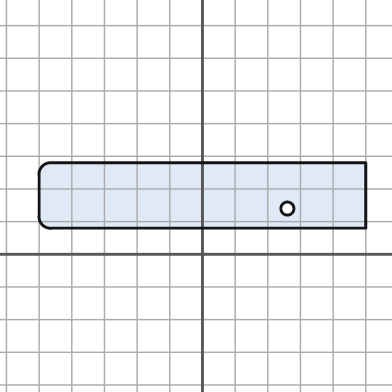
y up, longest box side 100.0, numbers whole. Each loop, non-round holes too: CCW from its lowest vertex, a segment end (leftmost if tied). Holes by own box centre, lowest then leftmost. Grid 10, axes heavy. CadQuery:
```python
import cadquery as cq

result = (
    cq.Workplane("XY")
    .moveTo(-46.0, 8.0)
    .lineTo(50.0, 8.0)
    .lineTo(50.0, 28.0)
    .lineTo(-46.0, 28.0)
    .threePointArc((-49.0, 27.0), (-50.0, 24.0))
    .lineTo(-50.0, 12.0)
    .threePointArc((-49.0, 9.0), (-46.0, 8.0))
    .close()
    .moveTo(26.0, 14.0)
    .circle(2.0)
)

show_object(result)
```